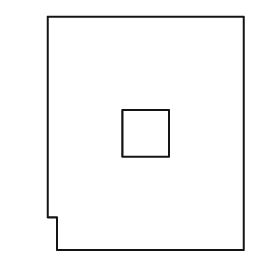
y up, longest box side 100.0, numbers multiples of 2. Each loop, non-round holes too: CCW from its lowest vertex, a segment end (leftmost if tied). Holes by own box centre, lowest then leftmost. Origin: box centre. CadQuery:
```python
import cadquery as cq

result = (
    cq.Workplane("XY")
    .moveTo(-38.0, -50.0)
    .lineTo(42.0, -50.0)
    .lineTo(42.0, 50.0)
    .lineTo(-42.0, 50.0)
    .lineTo(-42.0, -36.0)
    .lineTo(-38.0, -36.0)
    .close()
    .moveTo(-10.0, -10.0)
    .lineTo(10.0, -10.0)
    .lineTo(10.0, 10.0)
    .lineTo(-10.0, 10.0)
    .close()
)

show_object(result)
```